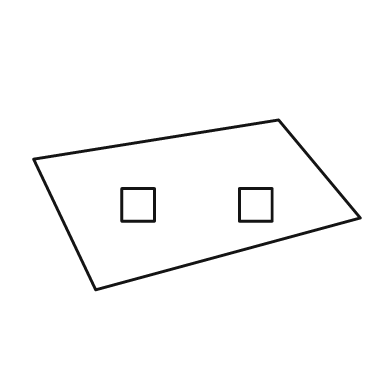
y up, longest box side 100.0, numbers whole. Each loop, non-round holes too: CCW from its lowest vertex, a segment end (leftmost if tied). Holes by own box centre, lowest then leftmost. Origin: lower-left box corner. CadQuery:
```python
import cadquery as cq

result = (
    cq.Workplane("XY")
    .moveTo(19.0, 0.0)
    .lineTo(100.0, 22.0)
    .lineTo(75.0, 52.0)
    .lineTo(0.0, 40.0)
    .close()
    .moveTo(27.0, 21.0)
    .lineTo(37.0, 21.0)
    .lineTo(37.0, 31.0)
    .lineTo(27.0, 31.0)
    .close()
    .moveTo(63.0, 21.0)
    .lineTo(73.0, 21.0)
    .lineTo(73.0, 31.0)
    .lineTo(63.0, 31.0)
    .close()
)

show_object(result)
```